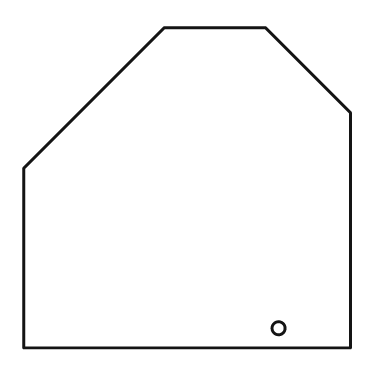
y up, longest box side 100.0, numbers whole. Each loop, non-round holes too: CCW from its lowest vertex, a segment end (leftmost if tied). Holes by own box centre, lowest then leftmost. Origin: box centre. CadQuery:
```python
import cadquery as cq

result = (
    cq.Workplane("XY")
    .moveTo(-50.0, -49.0)
    .lineTo(50.0, -49.0)
    .lineTo(50.0, 23.0)
    .lineTo(24.0, 49.0)
    .lineTo(-7.0, 49.0)
    .lineTo(-50.0, 6.0)
    .close()
    .moveTo(28.0, -43.0)
    .circle(2.0)
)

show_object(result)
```